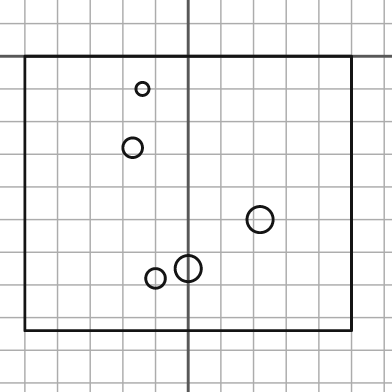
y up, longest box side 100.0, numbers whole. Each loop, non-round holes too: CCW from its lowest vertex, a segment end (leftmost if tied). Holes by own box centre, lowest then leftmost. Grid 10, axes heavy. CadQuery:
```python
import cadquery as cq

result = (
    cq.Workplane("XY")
    .moveTo(-50.0, -84.0)
    .lineTo(50.0, -84.0)
    .lineTo(50.0, 0.0)
    .lineTo(-50.0, 0.0)
    .close()
    .moveTo(-10.0, -68.0)
    .circle(3.0)
    .moveTo(0.0, -65.0)
    .circle(4.0)
    .moveTo(22.0, -50.0)
    .circle(4.0)
    .moveTo(-17.0, -28.0)
    .circle(3.0)
    .moveTo(-14.0, -10.0)
    .circle(2.0)
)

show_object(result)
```